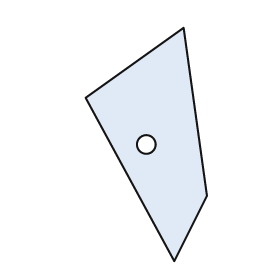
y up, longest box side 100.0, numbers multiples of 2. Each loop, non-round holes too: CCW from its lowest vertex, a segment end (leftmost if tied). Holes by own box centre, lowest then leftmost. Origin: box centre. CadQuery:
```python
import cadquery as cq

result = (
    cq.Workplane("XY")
    .moveTo(12.0, -50.0)
    .lineTo(26.0, -22.0)
    .lineTo(16.0, 50.0)
    .lineTo(-26.0, 20.0)
    .close()
    .moveTo(0.0, 0.0)
    .circle(4.0)
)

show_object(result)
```